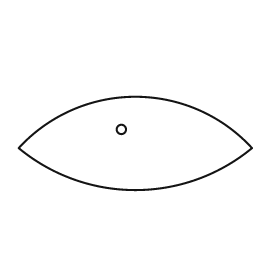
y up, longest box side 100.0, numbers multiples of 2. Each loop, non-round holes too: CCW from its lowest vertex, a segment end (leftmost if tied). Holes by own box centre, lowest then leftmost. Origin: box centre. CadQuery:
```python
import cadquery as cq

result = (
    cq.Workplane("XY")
    .moveTo(-50.0, -2.0)
    .threePointArc((0.0, -20.0), (50.0, -2.0))
    .threePointArc((0.0, 20.0), (-50.0, -2.0))
    .close()
    .moveTo(-6.0, 6.0)
    .circle(2.0)
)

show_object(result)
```